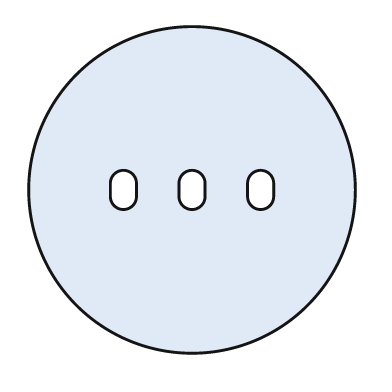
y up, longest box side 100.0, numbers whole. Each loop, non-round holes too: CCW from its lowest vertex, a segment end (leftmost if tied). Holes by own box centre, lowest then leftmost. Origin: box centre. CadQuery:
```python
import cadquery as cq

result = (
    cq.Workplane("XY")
    .moveTo(0.0, 0.0)
    .circle(50.0)
    .moveTo(-25.0, -2.0)
    .threePointArc((-21.0, -6.0), (-17.0, -2.0))
    .lineTo(-17.0, 2.0)
    .threePointArc((-21.0, 6.0), (-25.0, 2.0))
    .close()
    .moveTo(-4.0, -2.0)
    .threePointArc((0.0, -6.0), (4.0, -2.0))
    .lineTo(4.0, 2.0)
    .threePointArc((0.0, 6.0), (-4.0, 2.0))
    .close()
    .moveTo(17.0, -2.0)
    .threePointArc((21.0, -6.0), (25.0, -2.0))
    .lineTo(25.0, 2.0)
    .threePointArc((21.0, 6.0), (17.0, 2.0))
    .close()
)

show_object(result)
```